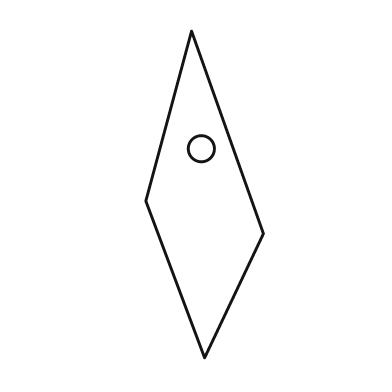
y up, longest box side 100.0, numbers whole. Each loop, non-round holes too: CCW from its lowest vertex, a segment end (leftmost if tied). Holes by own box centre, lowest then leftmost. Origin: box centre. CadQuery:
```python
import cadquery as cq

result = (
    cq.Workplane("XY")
    .moveTo(0.0, -50.0)
    .lineTo(18.0, -12.0)
    .lineTo(-4.0, 50.0)
    .lineTo(-18.0, -2.0)
    .close()
    .moveTo(-1.0, 14.0)
    .circle(4.0)
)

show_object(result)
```